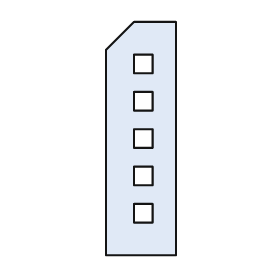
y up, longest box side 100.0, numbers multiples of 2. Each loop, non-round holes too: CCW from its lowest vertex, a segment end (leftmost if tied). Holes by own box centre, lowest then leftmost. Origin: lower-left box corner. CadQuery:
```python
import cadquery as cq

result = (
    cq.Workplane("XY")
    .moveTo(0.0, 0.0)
    .lineTo(30.0, 0.0)
    .lineTo(30.0, 100.0)
    .lineTo(12.0, 100.0)
    .lineTo(0.0, 88.0)
    .close()
    .moveTo(12.0, 14.0)
    .lineTo(20.0, 14.0)
    .lineTo(20.0, 22.0)
    .lineTo(12.0, 22.0)
    .close()
    .moveTo(12.0, 30.0)
    .lineTo(20.0, 30.0)
    .lineTo(20.0, 38.0)
    .lineTo(12.0, 38.0)
    .close()
    .moveTo(12.0, 46.0)
    .lineTo(20.0, 46.0)
    .lineTo(20.0, 54.0)
    .lineTo(12.0, 54.0)
    .close()
    .moveTo(12.0, 62.0)
    .lineTo(20.0, 62.0)
    .lineTo(20.0, 70.0)
    .lineTo(12.0, 70.0)
    .close()
    .moveTo(12.0, 78.0)
    .lineTo(20.0, 78.0)
    .lineTo(20.0, 86.0)
    .lineTo(12.0, 86.0)
    .close()
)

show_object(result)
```